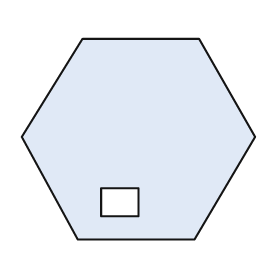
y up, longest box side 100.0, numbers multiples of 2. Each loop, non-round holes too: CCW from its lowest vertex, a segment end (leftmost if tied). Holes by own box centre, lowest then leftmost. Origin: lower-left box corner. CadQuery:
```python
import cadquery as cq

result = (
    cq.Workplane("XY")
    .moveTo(24.0, 0.0)
    .lineTo(74.0, 0.0)
    .lineTo(100.0, 44.0)
    .lineTo(76.0, 86.0)
    .lineTo(26.0, 86.0)
    .lineTo(0.0, 44.0)
    .close()
    .moveTo(34.0, 10.0)
    .lineTo(50.0, 10.0)
    .lineTo(50.0, 22.0)
    .lineTo(34.0, 22.0)
    .close()
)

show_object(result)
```